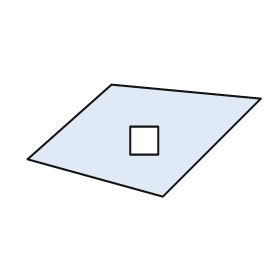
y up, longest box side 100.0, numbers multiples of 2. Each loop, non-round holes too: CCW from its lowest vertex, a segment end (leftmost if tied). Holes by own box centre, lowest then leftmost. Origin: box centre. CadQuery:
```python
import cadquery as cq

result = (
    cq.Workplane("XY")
    .moveTo(8.0, -24.0)
    .lineTo(50.0, 18.0)
    .lineTo(-14.0, 24.0)
    .lineTo(-50.0, -8.0)
    .close()
    .moveTo(-6.0, -6.0)
    .lineTo(6.0, -6.0)
    .lineTo(6.0, 6.0)
    .lineTo(-6.0, 6.0)
    .close()
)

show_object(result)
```